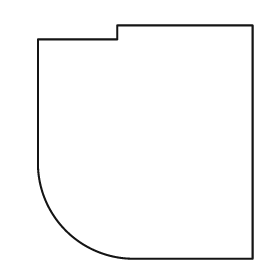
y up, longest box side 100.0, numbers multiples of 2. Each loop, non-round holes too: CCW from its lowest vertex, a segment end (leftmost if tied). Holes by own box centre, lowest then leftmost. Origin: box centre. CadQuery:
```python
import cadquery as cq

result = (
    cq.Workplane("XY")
    .moveTo(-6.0, -50.0)
    .lineTo(46.0, -50.0)
    .lineTo(46.0, 50.0)
    .lineTo(-12.0, 50.0)
    .lineTo(-12.0, 44.0)
    .lineTo(-46.0, 44.0)
    .lineTo(-46.0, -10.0)
    .threePointArc((-34.0, -38.0), (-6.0, -50.0))
    .close()
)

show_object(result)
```